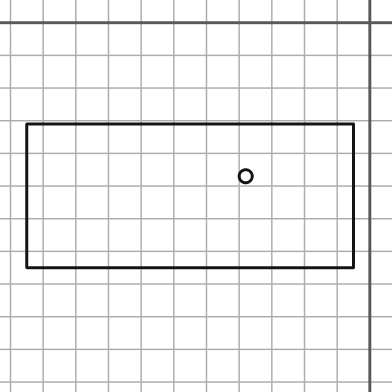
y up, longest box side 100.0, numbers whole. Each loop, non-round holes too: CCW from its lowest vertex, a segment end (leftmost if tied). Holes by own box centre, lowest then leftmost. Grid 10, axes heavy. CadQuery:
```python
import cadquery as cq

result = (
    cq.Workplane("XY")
    .moveTo(-105.0, -75.0)
    .lineTo(-5.0, -75.0)
    .lineTo(-5.0, -31.0)
    .lineTo(-105.0, -31.0)
    .close()
    .moveTo(-38.0, -47.0)
    .circle(2.0)
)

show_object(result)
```